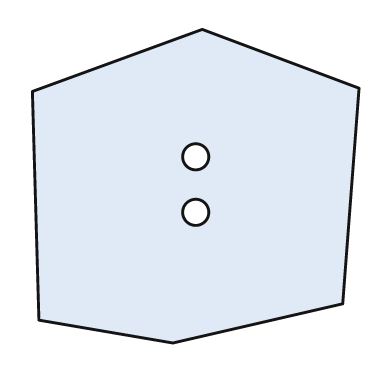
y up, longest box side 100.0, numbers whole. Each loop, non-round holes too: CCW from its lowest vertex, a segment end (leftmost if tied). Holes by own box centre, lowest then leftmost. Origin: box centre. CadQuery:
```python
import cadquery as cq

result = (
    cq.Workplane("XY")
    .moveTo(-7.0, -48.0)
    .lineTo(45.0, -36.0)
    .lineTo(50.0, 30.0)
    .lineTo(2.0, 48.0)
    .lineTo(-50.0, 29.0)
    .lineTo(-48.0, -41.0)
    .close()
    .moveTo(0.0, -8.0)
    .circle(4.0)
    .moveTo(0.0, 9.0)
    .circle(4.0)
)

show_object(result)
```